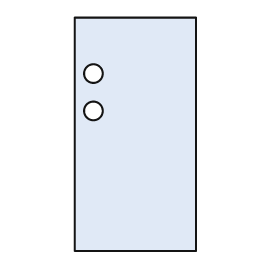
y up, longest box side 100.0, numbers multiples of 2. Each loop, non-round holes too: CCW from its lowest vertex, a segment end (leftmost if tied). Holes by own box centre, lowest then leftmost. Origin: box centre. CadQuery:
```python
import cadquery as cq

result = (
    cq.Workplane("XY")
    .moveTo(-26.0, -50.0)
    .lineTo(26.0, -50.0)
    .lineTo(26.0, 50.0)
    .lineTo(-26.0, 50.0)
    .close()
    .moveTo(-18.0, 10.0)
    .circle(4.0)
    .moveTo(-18.0, 26.0)
    .circle(4.0)
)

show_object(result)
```